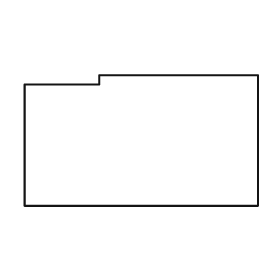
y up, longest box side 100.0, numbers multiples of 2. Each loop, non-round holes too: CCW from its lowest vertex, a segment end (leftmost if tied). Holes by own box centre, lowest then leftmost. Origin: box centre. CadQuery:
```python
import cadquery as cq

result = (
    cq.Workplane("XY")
    .moveTo(-50.0, -28.0)
    .lineTo(50.0, -28.0)
    .lineTo(50.0, 28.0)
    .lineTo(-18.0, 28.0)
    .lineTo(-18.0, 24.0)
    .lineTo(-50.0, 24.0)
    .close()
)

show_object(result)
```